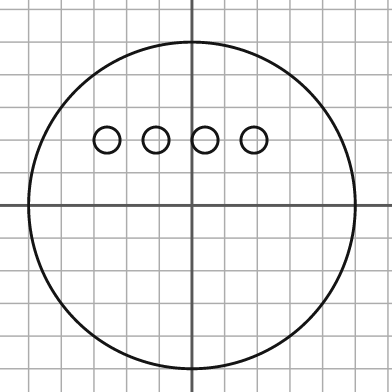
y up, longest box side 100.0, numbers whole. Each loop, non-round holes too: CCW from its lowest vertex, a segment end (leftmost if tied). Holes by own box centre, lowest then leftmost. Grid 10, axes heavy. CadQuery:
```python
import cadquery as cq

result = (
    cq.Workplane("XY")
    .moveTo(0.0, 0.0)
    .circle(50.0)
    .moveTo(-26.0, 20.0)
    .circle(4.0)
    .moveTo(-11.0, 20.0)
    .circle(4.0)
    .moveTo(4.0, 20.0)
    .circle(4.0)
    .moveTo(19.0, 20.0)
    .circle(4.0)
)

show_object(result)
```